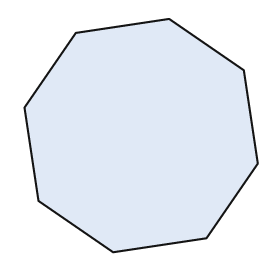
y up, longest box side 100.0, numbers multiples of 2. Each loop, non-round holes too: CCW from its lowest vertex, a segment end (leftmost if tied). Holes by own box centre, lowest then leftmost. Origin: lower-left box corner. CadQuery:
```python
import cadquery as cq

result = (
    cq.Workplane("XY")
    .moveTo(38.0, 0.0)
    .lineTo(78.0, 6.0)
    .lineTo(100.0, 38.0)
    .lineTo(94.0, 78.0)
    .lineTo(62.0, 100.0)
    .lineTo(22.0, 94.0)
    .lineTo(0.0, 62.0)
    .lineTo(6.0, 22.0)
    .close()
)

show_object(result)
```